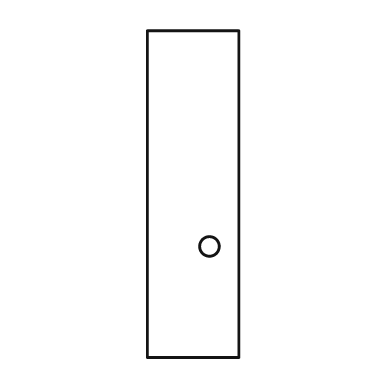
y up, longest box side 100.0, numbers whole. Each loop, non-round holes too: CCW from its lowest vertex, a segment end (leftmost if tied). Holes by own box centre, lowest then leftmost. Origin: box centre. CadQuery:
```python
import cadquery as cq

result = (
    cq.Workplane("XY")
    .moveTo(-14.0, -50.0)
    .lineTo(14.0, -50.0)
    .lineTo(14.0, 50.0)
    .lineTo(-14.0, 50.0)
    .close()
    .moveTo(5.0, -16.0)
    .circle(3.0)
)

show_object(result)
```